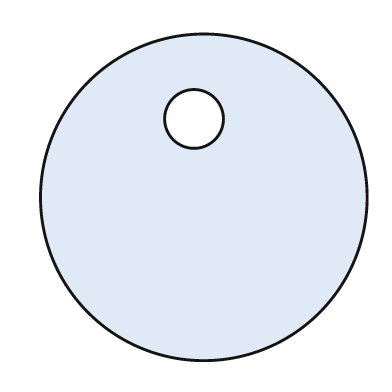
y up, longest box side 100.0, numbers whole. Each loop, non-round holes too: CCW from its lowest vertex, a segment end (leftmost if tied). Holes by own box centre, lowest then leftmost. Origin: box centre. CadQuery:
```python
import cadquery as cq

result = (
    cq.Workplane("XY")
    .moveTo(0.0, 0.0)
    .circle(50.0)
    .moveTo(-3.0, 24.0)
    .circle(9.0)
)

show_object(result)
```